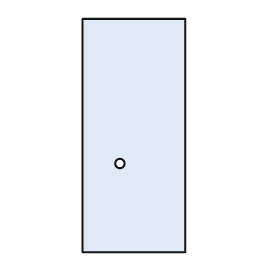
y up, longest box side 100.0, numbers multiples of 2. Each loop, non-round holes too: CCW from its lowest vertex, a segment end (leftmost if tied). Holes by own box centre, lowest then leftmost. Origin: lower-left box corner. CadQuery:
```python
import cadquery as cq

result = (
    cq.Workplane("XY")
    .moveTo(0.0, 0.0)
    .lineTo(44.0, 0.0)
    .lineTo(44.0, 100.0)
    .lineTo(0.0, 100.0)
    .close()
    .moveTo(16.0, 38.0)
    .circle(2.0)
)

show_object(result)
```